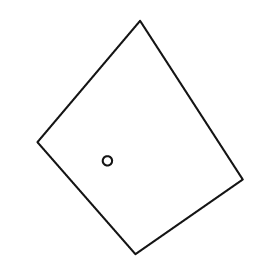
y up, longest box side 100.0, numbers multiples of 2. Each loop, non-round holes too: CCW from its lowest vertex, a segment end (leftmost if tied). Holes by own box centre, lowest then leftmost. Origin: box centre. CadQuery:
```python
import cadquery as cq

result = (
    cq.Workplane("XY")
    .moveTo(-2.0, -50.0)
    .lineTo(44.0, -18.0)
    .lineTo(0.0, 50.0)
    .lineTo(-44.0, -2.0)
    .close()
    .moveTo(-14.0, -10.0)
    .circle(2.0)
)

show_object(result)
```